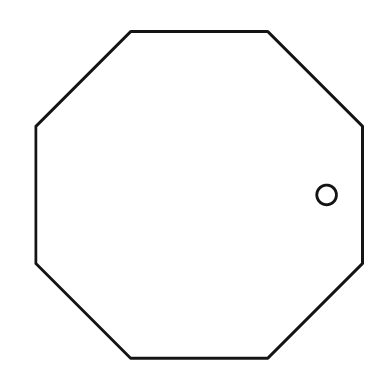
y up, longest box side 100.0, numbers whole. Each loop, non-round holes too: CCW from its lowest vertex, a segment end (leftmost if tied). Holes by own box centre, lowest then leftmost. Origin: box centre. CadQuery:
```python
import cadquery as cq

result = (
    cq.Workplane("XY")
    .moveTo(-21.0, -50.0)
    .lineTo(21.0, -50.0)
    .lineTo(50.0, -21.0)
    .lineTo(50.0, 21.0)
    .lineTo(21.0, 50.0)
    .lineTo(-21.0, 50.0)
    .lineTo(-50.0, 21.0)
    .lineTo(-50.0, -21.0)
    .close()
    .moveTo(39.0, 0.0)
    .circle(3.0)
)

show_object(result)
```